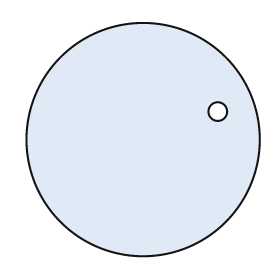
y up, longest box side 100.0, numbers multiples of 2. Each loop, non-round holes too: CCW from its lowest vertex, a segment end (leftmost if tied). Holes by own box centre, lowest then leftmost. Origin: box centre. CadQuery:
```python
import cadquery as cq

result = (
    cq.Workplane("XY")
    .moveTo(0.0, 0.0)
    .circle(50.0)
    .moveTo(32.0, 12.0)
    .circle(4.0)
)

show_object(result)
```